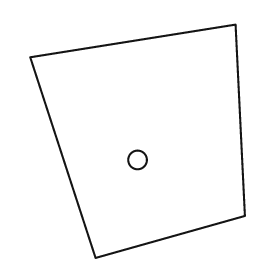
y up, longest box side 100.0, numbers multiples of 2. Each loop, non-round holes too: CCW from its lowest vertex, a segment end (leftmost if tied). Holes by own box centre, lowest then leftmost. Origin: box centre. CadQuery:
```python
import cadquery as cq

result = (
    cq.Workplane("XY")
    .moveTo(-18.0, -50.0)
    .lineTo(46.0, -32.0)
    .lineTo(42.0, 50.0)
    .lineTo(-46.0, 36.0)
    .close()
    .moveTo(0.0, -8.0)
    .circle(4.0)
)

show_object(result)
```